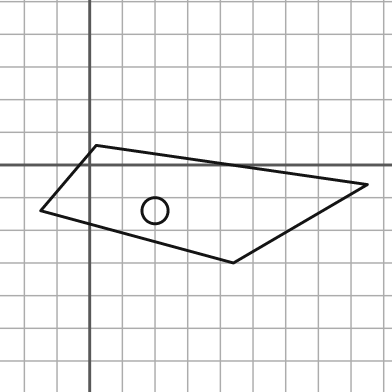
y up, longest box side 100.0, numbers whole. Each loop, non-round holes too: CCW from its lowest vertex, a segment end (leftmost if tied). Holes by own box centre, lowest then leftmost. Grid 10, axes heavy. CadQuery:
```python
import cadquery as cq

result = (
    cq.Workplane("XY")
    .moveTo(44.0, -30.0)
    .lineTo(85.0, -6.0)
    .lineTo(2.0, 6.0)
    .lineTo(-15.0, -14.0)
    .close()
    .moveTo(20.0, -14.0)
    .circle(4.0)
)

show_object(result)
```